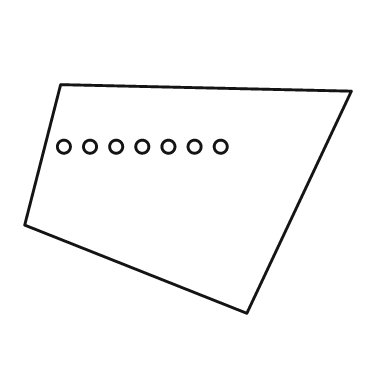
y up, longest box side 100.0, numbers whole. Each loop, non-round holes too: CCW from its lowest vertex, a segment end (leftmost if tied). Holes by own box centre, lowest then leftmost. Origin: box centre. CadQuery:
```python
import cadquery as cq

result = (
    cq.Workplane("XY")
    .moveTo(18.0, -35.0)
    .lineTo(50.0, 33.0)
    .lineTo(-39.0, 35.0)
    .lineTo(-50.0, -8.0)
    .close()
    .moveTo(-38.0, 16.0)
    .circle(2.0)
    .moveTo(-30.0, 16.0)
    .circle(2.0)
    .moveTo(-22.0, 16.0)
    .circle(2.0)
    .moveTo(-14.0, 16.0)
    .circle(2.0)
    .moveTo(-6.0, 16.0)
    .circle(2.0)
    .moveTo(2.0, 16.0)
    .circle(2.0)
    .moveTo(10.0, 16.0)
    .circle(2.0)
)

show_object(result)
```